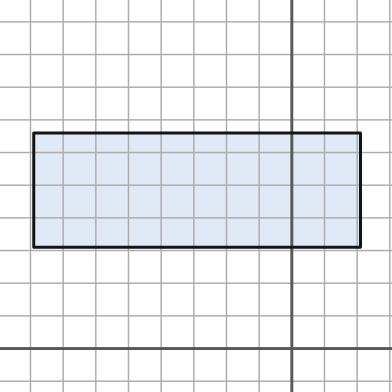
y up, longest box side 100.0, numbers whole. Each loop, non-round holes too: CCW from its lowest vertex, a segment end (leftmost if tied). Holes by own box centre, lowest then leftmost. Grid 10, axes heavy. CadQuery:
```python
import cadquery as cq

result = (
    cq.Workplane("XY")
    .moveTo(-79.0, 31.0)
    .lineTo(21.0, 31.0)
    .lineTo(21.0, 66.0)
    .lineTo(-79.0, 66.0)
    .close()
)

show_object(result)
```